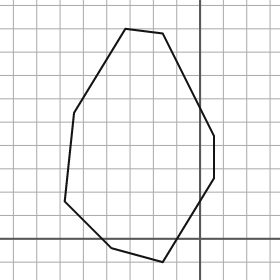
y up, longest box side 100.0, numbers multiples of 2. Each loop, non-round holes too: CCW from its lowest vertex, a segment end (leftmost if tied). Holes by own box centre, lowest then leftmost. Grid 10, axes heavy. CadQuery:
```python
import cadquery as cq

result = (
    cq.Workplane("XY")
    .moveTo(-16.0, -10.0)
    .lineTo(6.0, 26.0)
    .lineTo(6.0, 44.0)
    .lineTo(-16.0, 88.0)
    .lineTo(-32.0, 90.0)
    .lineTo(-54.0, 54.0)
    .lineTo(-58.0, 16.0)
    .lineTo(-38.0, -4.0)
    .close()
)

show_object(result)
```